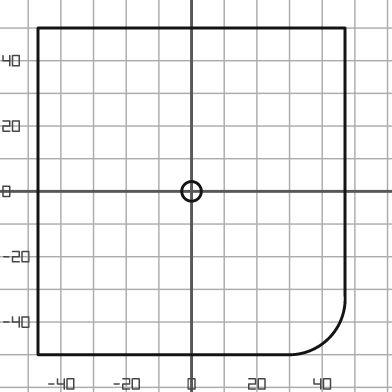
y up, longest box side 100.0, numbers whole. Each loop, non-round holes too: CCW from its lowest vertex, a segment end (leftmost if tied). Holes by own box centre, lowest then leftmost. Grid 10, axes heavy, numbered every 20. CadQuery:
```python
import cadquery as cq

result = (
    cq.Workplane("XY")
    .moveTo(-47.0, -50.0)
    .lineTo(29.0, -50.0)
    .threePointArc((42.0, -45.0), (47.0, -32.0))
    .lineTo(47.0, 50.0)
    .lineTo(-47.0, 50.0)
    .close()
    .moveTo(0.0, 0.0)
    .circle(3.0)
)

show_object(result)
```